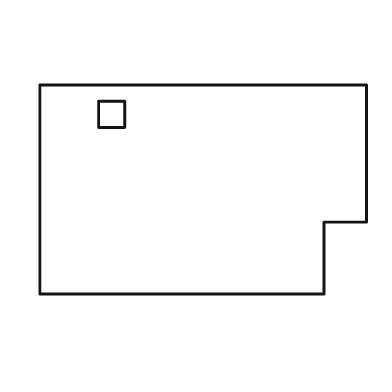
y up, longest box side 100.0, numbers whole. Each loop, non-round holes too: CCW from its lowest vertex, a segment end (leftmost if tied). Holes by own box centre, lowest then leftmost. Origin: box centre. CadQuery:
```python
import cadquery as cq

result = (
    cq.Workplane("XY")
    .moveTo(-50.0, -32.0)
    .lineTo(37.0, -32.0)
    .lineTo(37.0, -10.0)
    .lineTo(50.0, -10.0)
    .lineTo(50.0, 32.0)
    .lineTo(-50.0, 32.0)
    .close()
    .moveTo(-32.0, 19.0)
    .lineTo(-24.0, 19.0)
    .lineTo(-24.0, 27.0)
    .lineTo(-32.0, 27.0)
    .close()
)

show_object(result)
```